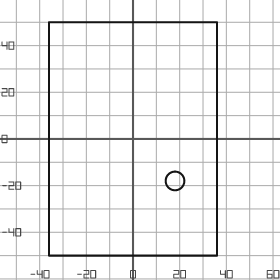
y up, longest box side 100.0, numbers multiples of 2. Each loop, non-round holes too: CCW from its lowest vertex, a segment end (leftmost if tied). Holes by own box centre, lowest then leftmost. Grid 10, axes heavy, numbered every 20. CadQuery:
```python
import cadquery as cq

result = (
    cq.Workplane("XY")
    .moveTo(-36.0, -50.0)
    .lineTo(36.0, -50.0)
    .lineTo(36.0, 50.0)
    .lineTo(-36.0, 50.0)
    .close()
    .moveTo(18.0, -18.0)
    .circle(4.0)
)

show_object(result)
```